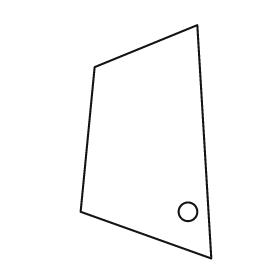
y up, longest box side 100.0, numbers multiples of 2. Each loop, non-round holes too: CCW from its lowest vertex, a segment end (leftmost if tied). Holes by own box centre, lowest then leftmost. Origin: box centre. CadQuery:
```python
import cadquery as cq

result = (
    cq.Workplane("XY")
    .moveTo(28.0, -50.0)
    .lineTo(22.0, 50.0)
    .lineTo(-22.0, 32.0)
    .lineTo(-28.0, -30.0)
    .close()
    .moveTo(18.0, -30.0)
    .circle(4.0)
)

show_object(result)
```